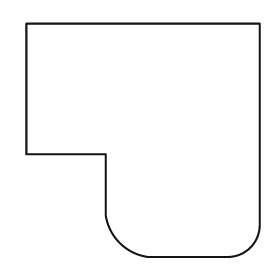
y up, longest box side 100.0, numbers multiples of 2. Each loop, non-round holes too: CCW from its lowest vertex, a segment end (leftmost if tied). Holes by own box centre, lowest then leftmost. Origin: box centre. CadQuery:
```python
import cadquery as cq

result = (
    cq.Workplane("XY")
    .moveTo(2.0, -50.0)
    .lineTo(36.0, -50.0)
    .threePointArc((46.0, -46.0), (50.0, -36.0))
    .lineTo(50.0, 50.0)
    .lineTo(-50.0, 50.0)
    .lineTo(-50.0, -6.0)
    .lineTo(-16.0, -6.0)
    .lineTo(-16.0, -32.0)
    .threePointArc((-10.0, -44.0), (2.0, -50.0))
    .close()
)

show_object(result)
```